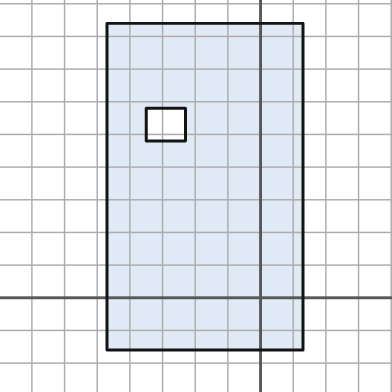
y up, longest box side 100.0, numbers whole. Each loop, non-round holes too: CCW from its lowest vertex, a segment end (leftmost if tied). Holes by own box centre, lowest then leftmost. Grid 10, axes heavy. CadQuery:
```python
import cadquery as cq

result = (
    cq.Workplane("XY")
    .moveTo(-47.0, -16.0)
    .lineTo(13.0, -16.0)
    .lineTo(13.0, 84.0)
    .lineTo(-47.0, 84.0)
    .close()
    .moveTo(-35.0, 48.0)
    .lineTo(-23.0, 48.0)
    .lineTo(-23.0, 58.0)
    .lineTo(-35.0, 58.0)
    .close()
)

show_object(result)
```